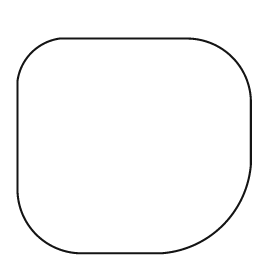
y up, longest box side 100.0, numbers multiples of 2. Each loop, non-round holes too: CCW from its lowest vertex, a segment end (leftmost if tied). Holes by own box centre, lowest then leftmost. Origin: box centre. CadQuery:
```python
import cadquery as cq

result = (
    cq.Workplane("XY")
    .moveTo(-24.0, -46.0)
    .lineTo(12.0, -46.0)
    .threePointArc((38.0, -34.0), (50.0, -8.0))
    .lineTo(50.0, 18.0)
    .threePointArc((42.0, 38.0), (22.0, 46.0))
    .lineTo(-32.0, 46.0)
    .threePointArc((-44.0, 40.0), (-50.0, 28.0))
    .lineTo(-50.0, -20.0)
    .threePointArc((-42.0, -38.0), (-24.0, -46.0))
    .close()
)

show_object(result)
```